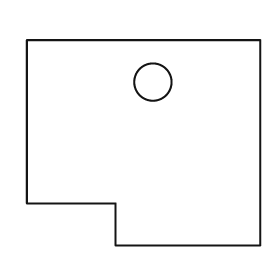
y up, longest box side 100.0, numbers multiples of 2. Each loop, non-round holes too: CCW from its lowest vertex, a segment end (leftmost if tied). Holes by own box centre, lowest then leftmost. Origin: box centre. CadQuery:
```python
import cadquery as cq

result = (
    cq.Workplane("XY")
    .moveTo(-12.0, -44.0)
    .lineTo(50.0, -44.0)
    .lineTo(50.0, 44.0)
    .lineTo(-50.0, 44.0)
    .lineTo(-50.0, -26.0)
    .lineTo(-12.0, -26.0)
    .close()
    .moveTo(4.0, 26.0)
    .circle(8.0)
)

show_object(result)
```